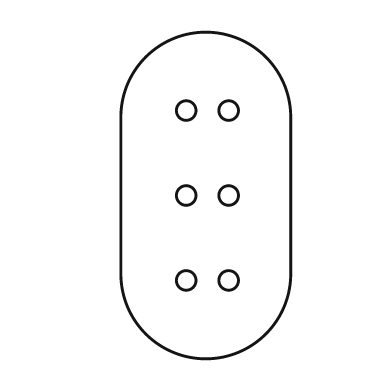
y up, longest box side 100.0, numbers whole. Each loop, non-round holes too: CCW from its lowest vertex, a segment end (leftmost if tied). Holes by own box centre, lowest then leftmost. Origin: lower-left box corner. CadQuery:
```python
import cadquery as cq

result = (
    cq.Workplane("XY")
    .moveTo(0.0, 26.0)
    .threePointArc((26.0, 0.0), (52.0, 26.0))
    .lineTo(52.0, 74.0)
    .threePointArc((26.0, 100.0), (0.0, 74.0))
    .close()
    .moveTo(20.0, 24.0)
    .circle(3.0)
    .moveTo(33.0, 24.0)
    .circle(3.0)
    .moveTo(20.0, 50.0)
    .circle(3.0)
    .moveTo(33.0, 50.0)
    .circle(3.0)
    .moveTo(20.0, 76.0)
    .circle(3.0)
    .moveTo(33.0, 76.0)
    .circle(3.0)
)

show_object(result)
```